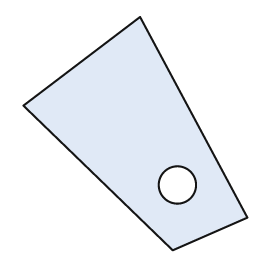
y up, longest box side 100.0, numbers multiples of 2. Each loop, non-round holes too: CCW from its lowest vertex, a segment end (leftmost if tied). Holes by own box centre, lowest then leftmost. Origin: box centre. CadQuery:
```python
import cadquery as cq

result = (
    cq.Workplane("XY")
    .moveTo(16.0, -50.0)
    .lineTo(48.0, -36.0)
    .lineTo(2.0, 50.0)
    .lineTo(-48.0, 12.0)
    .close()
    .moveTo(18.0, -22.0)
    .circle(8.0)
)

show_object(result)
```